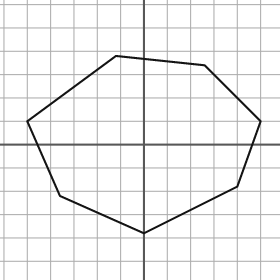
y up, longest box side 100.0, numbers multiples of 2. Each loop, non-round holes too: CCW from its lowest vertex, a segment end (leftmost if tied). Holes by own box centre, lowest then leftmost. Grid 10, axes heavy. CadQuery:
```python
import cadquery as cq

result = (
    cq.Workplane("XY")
    .moveTo(0.0, -38.0)
    .lineTo(40.0, -18.0)
    .lineTo(50.0, 10.0)
    .lineTo(26.0, 34.0)
    .lineTo(-12.0, 38.0)
    .lineTo(-50.0, 10.0)
    .lineTo(-36.0, -22.0)
    .close()
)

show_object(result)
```